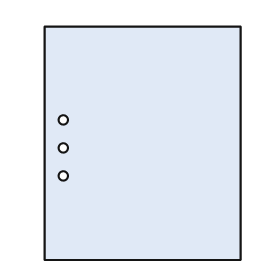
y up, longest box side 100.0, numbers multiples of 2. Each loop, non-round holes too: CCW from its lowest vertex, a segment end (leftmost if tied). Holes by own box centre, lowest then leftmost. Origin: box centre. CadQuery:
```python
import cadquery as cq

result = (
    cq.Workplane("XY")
    .moveTo(-42.0, -50.0)
    .lineTo(42.0, -50.0)
    .lineTo(42.0, 50.0)
    .lineTo(-42.0, 50.0)
    .close()
    .moveTo(-34.0, -14.0)
    .circle(2.0)
    .moveTo(-34.0, -2.0)
    .circle(2.0)
    .moveTo(-34.0, 10.0)
    .circle(2.0)
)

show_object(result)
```